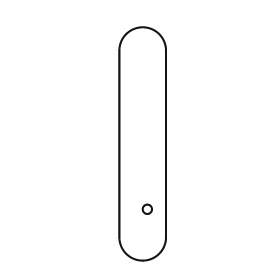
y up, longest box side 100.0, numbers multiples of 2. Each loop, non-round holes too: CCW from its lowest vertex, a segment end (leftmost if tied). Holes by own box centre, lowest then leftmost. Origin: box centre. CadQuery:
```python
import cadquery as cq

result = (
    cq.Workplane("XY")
    .moveTo(-10.0, -40.0)
    .threePointArc((0.0, -50.0), (10.0, -40.0))
    .lineTo(10.0, 40.0)
    .threePointArc((0.0, 50.0), (-10.0, 40.0))
    .close()
    .moveTo(2.0, -28.0)
    .circle(2.0)
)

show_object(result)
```